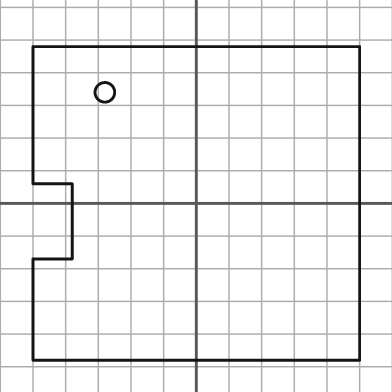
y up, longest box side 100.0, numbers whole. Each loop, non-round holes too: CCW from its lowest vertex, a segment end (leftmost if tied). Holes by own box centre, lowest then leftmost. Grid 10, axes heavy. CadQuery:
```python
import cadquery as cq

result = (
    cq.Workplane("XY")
    .moveTo(-50.0, -48.0)
    .lineTo(50.0, -48.0)
    .lineTo(50.0, 48.0)
    .lineTo(-50.0, 48.0)
    .lineTo(-50.0, 6.0)
    .lineTo(-38.0, 6.0)
    .lineTo(-38.0, -17.0)
    .lineTo(-50.0, -17.0)
    .close()
    .moveTo(-28.0, 34.0)
    .circle(3.0)
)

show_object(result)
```